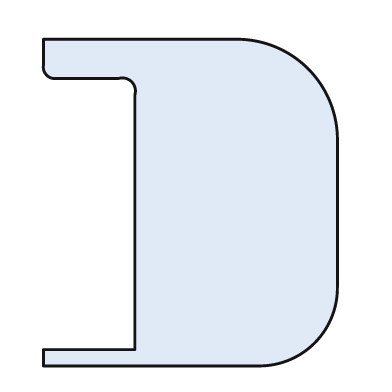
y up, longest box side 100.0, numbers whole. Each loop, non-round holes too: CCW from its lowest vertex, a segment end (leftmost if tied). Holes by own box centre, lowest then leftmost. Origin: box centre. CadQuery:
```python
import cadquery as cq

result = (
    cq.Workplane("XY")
    .moveTo(-45.0, -50.0)
    .lineTo(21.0, -50.0)
    .threePointArc((38.0, -43.0), (45.0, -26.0))
    .lineTo(45.0, 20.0)
    .threePointArc((36.0, 41.0), (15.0, 50.0))
    .lineTo(-45.0, 50.0)
    .lineTo(-45.0, 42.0)
    .threePointArc((-44.0, 39.0), (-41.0, 38.0))
    .lineTo(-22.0, 38.0)
    .threePointArc((-18.0, 37.0), (-17.0, 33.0))
    .lineTo(-17.0, -45.0)
    .lineTo(-45.0, -45.0)
    .close()
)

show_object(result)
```